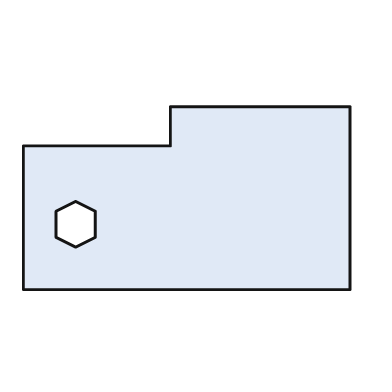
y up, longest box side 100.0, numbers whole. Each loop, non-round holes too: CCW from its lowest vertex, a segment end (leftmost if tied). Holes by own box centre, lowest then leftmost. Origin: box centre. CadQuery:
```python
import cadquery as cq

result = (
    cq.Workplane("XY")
    .moveTo(-50.0, -28.0)
    .lineTo(50.0, -28.0)
    .lineTo(50.0, 28.0)
    .lineTo(-5.0, 28.0)
    .lineTo(-5.0, 16.0)
    .lineTo(-50.0, 16.0)
    .close()
    .moveTo(-34.0, -15.0)
    .lineTo(-28.0, -12.0)
    .lineTo(-28.0, -4.0)
    .lineTo(-34.0, -1.0)
    .lineTo(-40.0, -4.0)
    .lineTo(-40.0, -12.0)
    .close()
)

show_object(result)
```